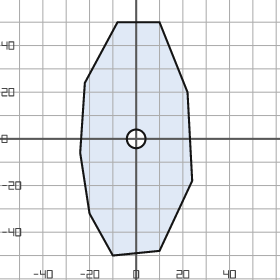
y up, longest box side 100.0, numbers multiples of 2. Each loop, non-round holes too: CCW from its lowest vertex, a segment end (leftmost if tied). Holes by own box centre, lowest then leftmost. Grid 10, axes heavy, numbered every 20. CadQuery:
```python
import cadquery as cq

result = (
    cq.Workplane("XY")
    .moveTo(-10.0, -50.0)
    .lineTo(10.0, -48.0)
    .lineTo(24.0, -18.0)
    .lineTo(22.0, 20.0)
    .lineTo(10.0, 50.0)
    .lineTo(-8.0, 50.0)
    .lineTo(-22.0, 24.0)
    .lineTo(-24.0, -6.0)
    .lineTo(-20.0, -32.0)
    .close()
    .moveTo(0.0, 0.0)
    .circle(4.0)
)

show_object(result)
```